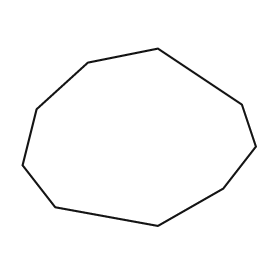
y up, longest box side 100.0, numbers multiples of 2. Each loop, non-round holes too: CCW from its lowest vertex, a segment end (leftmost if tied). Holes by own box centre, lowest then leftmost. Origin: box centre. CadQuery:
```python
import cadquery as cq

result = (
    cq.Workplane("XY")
    .moveTo(8.0, -38.0)
    .lineTo(36.0, -22.0)
    .lineTo(50.0, -4.0)
    .lineTo(44.0, 14.0)
    .lineTo(8.0, 38.0)
    .lineTo(-22.0, 32.0)
    .lineTo(-44.0, 12.0)
    .lineTo(-50.0, -12.0)
    .lineTo(-36.0, -30.0)
    .close()
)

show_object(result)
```